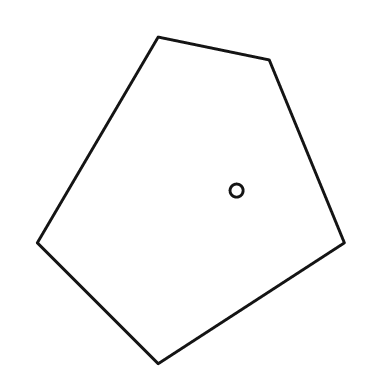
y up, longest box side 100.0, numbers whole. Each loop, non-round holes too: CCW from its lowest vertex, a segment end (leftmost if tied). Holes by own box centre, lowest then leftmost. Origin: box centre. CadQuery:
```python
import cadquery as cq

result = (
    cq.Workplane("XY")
    .moveTo(-10.0, -50.0)
    .lineTo(47.0, -13.0)
    .lineTo(24.0, 43.0)
    .lineTo(-10.0, 50.0)
    .lineTo(-47.0, -13.0)
    .close()
    .moveTo(14.0, 3.0)
    .circle(2.0)
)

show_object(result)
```